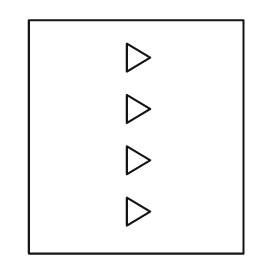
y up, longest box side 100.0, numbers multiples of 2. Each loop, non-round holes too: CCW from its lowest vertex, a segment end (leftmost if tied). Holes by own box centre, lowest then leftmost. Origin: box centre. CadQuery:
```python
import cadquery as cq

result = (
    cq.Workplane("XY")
    .moveTo(-46.0, -50.0)
    .lineTo(46.0, -50.0)
    .lineTo(46.0, 50.0)
    .lineTo(-46.0, 50.0)
    .close()
    .moveTo(-4.0, -38.0)
    .lineTo(6.0, -32.0)
    .lineTo(-4.0, -26.0)
    .close()
    .moveTo(-4.0, -16.0)
    .lineTo(6.0, -10.0)
    .lineTo(-4.0, -4.0)
    .close()
    .moveTo(-4.0, 6.0)
    .lineTo(6.0, 12.0)
    .lineTo(-4.0, 18.0)
    .close()
    .moveTo(-4.0, 28.0)
    .lineTo(6.0, 34.0)
    .lineTo(-4.0, 40.0)
    .close()
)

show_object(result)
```